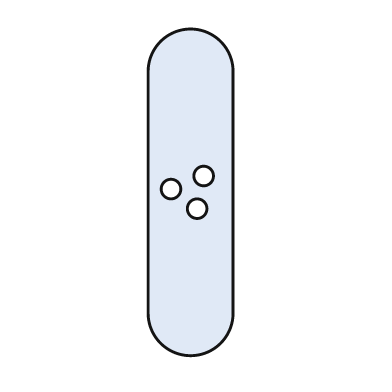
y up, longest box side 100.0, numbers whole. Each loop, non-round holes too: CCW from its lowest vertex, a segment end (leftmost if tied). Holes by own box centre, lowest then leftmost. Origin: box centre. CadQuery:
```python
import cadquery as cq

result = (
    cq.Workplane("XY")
    .moveTo(-13.0, -37.0)
    .threePointArc((0.0, -50.0), (13.0, -37.0))
    .lineTo(13.0, 37.0)
    .threePointArc((0.0, 50.0), (-13.0, 37.0))
    .close()
    .moveTo(2.0, -5.0)
    .circle(3.0)
    .moveTo(-6.0, 1.0)
    .circle(3.0)
    .moveTo(4.0, 5.0)
    .circle(3.0)
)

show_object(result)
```